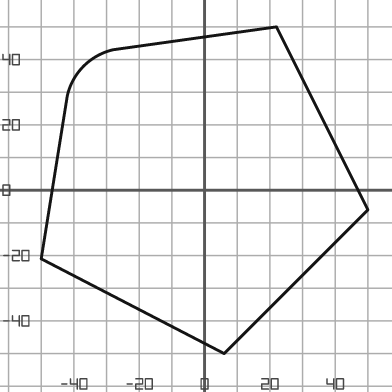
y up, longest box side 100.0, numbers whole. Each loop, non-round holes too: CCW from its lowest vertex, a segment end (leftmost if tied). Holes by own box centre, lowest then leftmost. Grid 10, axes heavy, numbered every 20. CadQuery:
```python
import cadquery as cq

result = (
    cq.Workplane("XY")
    .moveTo(6.0, -50.0)
    .lineTo(50.0, -6.0)
    .lineTo(22.0, 50.0)
    .lineTo(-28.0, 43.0)
    .threePointArc((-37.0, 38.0), (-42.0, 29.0))
    .lineTo(-50.0, -21.0)
    .close()
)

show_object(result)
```